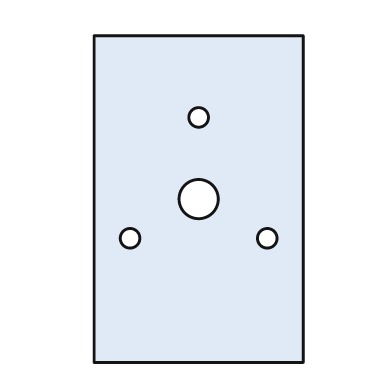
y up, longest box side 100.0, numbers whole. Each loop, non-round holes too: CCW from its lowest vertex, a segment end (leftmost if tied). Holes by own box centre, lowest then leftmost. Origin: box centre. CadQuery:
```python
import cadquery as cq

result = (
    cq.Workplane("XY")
    .moveTo(-32.0, -50.0)
    .lineTo(32.0, -50.0)
    .lineTo(32.0, 50.0)
    .lineTo(-32.0, 50.0)
    .close()
    .moveTo(-21.0, -12.0)
    .circle(3.0)
    .moveTo(21.0, -12.0)
    .circle(3.0)
    .moveTo(0.0, 0.0)
    .circle(6.0)
    .moveTo(0.0, 25.0)
    .circle(3.0)
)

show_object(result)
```